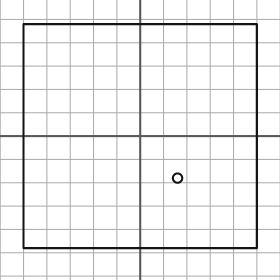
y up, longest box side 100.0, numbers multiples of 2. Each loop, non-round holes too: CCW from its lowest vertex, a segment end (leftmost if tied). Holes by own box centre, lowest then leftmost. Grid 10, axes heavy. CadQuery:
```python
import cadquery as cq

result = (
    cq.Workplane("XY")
    .moveTo(-50.0, -48.0)
    .lineTo(50.0, -48.0)
    .lineTo(50.0, 48.0)
    .lineTo(-50.0, 48.0)
    .close()
    .moveTo(16.0, -18.0)
    .circle(2.0)
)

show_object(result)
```